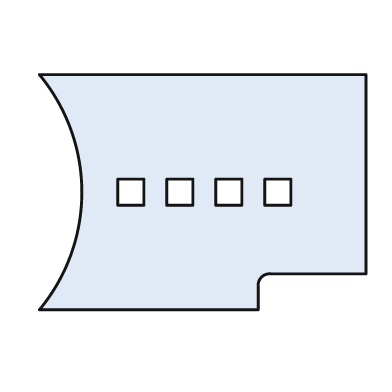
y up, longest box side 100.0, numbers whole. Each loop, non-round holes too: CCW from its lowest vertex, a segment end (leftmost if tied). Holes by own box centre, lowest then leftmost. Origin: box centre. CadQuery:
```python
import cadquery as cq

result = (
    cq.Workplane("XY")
    .moveTo(-50.0, -36.0)
    .lineTo(17.0, -36.0)
    .lineTo(17.0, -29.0)
    .threePointArc((18.0, -26.0), (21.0, -25.0))
    .lineTo(50.0, -25.0)
    .lineTo(50.0, 36.0)
    .lineTo(-50.0, 36.0)
    .threePointArc((-37.0, 0.0), (-50.0, -36.0))
    .close()
    .moveTo(-26.0, -4.0)
    .lineTo(-18.0, -4.0)
    .lineTo(-18.0, 4.0)
    .lineTo(-26.0, 4.0)
    .close()
    .moveTo(-11.0, -4.0)
    .lineTo(-3.0, -4.0)
    .lineTo(-3.0, 4.0)
    .lineTo(-11.0, 4.0)
    .close()
    .moveTo(4.0, -4.0)
    .lineTo(12.0, -4.0)
    .lineTo(12.0, 4.0)
    .lineTo(4.0, 4.0)
    .close()
    .moveTo(19.0, -4.0)
    .lineTo(27.0, -4.0)
    .lineTo(27.0, 4.0)
    .lineTo(19.0, 4.0)
    .close()
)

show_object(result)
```